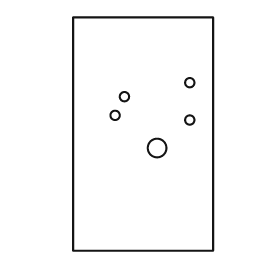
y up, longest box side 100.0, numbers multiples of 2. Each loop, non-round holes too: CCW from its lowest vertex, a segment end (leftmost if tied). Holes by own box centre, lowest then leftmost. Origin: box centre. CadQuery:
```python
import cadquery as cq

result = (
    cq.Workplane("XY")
    .moveTo(-30.0, -50.0)
    .lineTo(30.0, -50.0)
    .lineTo(30.0, 50.0)
    .lineTo(-30.0, 50.0)
    .close()
    .moveTo(6.0, -6.0)
    .circle(4.0)
    .moveTo(20.0, 6.0)
    .circle(2.0)
    .moveTo(-12.0, 8.0)
    .circle(2.0)
    .moveTo(-8.0, 16.0)
    .circle(2.0)
    .moveTo(20.0, 22.0)
    .circle(2.0)
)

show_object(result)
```